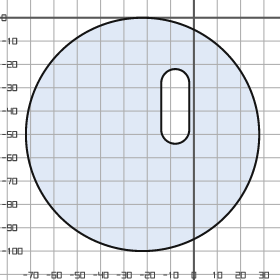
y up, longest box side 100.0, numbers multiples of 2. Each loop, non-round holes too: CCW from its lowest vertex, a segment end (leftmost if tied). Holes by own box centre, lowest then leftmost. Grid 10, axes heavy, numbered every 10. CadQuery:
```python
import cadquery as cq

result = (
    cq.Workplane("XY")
    .moveTo(-22.0, -50.0)
    .circle(50.0)
    .moveTo(-14.0, -48.0)
    .threePointArc((-8.0, -54.0), (-2.0, -48.0))
    .lineTo(-2.0, -28.0)
    .threePointArc((-8.0, -22.0), (-14.0, -28.0))
    .close()
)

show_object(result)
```